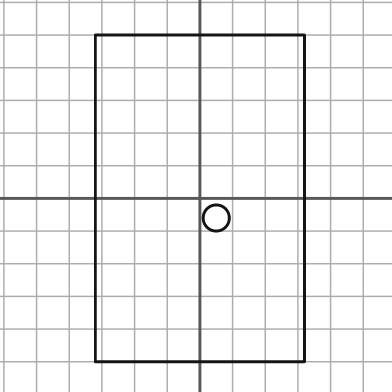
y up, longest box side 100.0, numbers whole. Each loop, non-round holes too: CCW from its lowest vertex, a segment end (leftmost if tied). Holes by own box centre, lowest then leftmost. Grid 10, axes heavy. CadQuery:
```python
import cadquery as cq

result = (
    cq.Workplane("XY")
    .moveTo(-32.0, -50.0)
    .lineTo(32.0, -50.0)
    .lineTo(32.0, 50.0)
    .lineTo(-32.0, 50.0)
    .close()
    .moveTo(5.0, -6.0)
    .circle(4.0)
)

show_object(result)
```